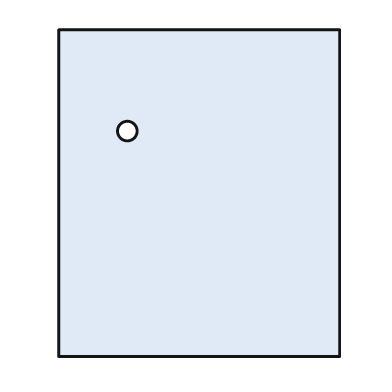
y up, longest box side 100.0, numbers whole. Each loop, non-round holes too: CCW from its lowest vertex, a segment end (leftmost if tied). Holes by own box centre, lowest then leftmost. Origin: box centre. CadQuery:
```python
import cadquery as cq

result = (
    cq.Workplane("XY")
    .moveTo(-43.0, -50.0)
    .lineTo(43.0, -50.0)
    .lineTo(43.0, 50.0)
    .lineTo(-43.0, 50.0)
    .close()
    .moveTo(-22.0, 19.0)
    .circle(3.0)
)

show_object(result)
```